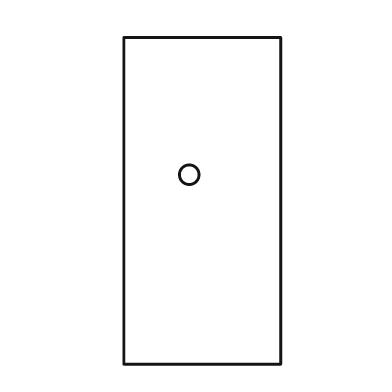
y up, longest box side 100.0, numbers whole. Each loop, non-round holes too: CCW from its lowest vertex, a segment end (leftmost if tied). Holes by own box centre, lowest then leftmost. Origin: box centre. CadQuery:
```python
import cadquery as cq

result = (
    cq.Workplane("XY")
    .moveTo(-24.0, -50.0)
    .lineTo(24.0, -50.0)
    .lineTo(24.0, 50.0)
    .lineTo(-24.0, 50.0)
    .close()
    .moveTo(-4.0, 8.0)
    .circle(3.0)
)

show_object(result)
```